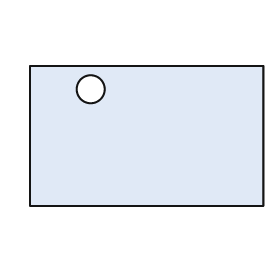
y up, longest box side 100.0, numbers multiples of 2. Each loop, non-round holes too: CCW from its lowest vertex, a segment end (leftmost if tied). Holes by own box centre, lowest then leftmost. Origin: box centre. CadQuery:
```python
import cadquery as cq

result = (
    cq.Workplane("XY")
    .moveTo(-50.0, -30.0)
    .lineTo(50.0, -30.0)
    .lineTo(50.0, 30.0)
    .lineTo(-50.0, 30.0)
    .close()
    .moveTo(-24.0, 20.0)
    .circle(6.0)
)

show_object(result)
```